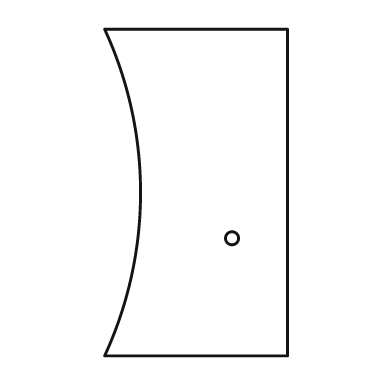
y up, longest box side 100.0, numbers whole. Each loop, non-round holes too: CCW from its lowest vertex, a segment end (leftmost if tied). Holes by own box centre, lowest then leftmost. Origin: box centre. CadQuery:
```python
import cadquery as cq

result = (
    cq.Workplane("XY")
    .moveTo(-28.0, -50.0)
    .lineTo(28.0, -50.0)
    .lineTo(28.0, 50.0)
    .lineTo(-28.0, 50.0)
    .threePointArc((-17.0, 0.0), (-28.0, -50.0))
    .close()
    .moveTo(11.0, -14.0)
    .circle(2.0)
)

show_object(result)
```